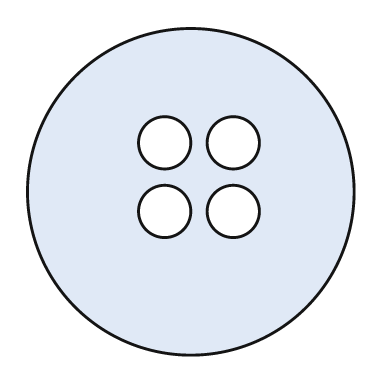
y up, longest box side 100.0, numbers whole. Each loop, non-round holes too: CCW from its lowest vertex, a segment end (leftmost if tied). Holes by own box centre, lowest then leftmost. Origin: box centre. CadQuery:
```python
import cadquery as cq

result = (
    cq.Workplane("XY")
    .moveTo(0.0, 0.0)
    .circle(50.0)
    .moveTo(-8.0, -6.0)
    .circle(8.0)
    .moveTo(13.0, -6.0)
    .circle(8.0)
    .moveTo(-8.0, 15.0)
    .circle(8.0)
    .moveTo(13.0, 15.0)
    .circle(8.0)
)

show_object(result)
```